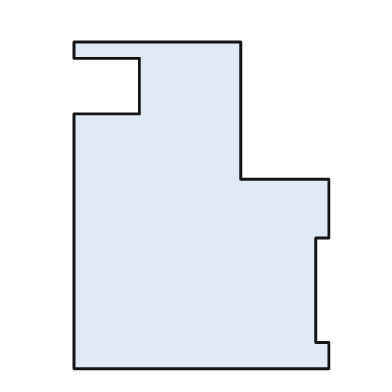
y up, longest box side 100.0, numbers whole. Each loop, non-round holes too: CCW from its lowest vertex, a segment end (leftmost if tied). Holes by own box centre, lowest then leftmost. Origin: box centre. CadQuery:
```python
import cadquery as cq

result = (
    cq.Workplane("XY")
    .moveTo(-39.0, -50.0)
    .lineTo(39.0, -50.0)
    .lineTo(39.0, -42.0)
    .lineTo(35.0, -42.0)
    .lineTo(35.0, -10.0)
    .lineTo(39.0, -10.0)
    .lineTo(39.0, 8.0)
    .lineTo(12.0, 8.0)
    .lineTo(12.0, 50.0)
    .lineTo(-39.0, 50.0)
    .lineTo(-39.0, 45.0)
    .lineTo(-19.0, 45.0)
    .lineTo(-19.0, 28.0)
    .lineTo(-39.0, 28.0)
    .close()
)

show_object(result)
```